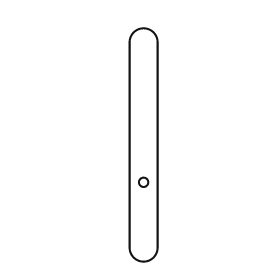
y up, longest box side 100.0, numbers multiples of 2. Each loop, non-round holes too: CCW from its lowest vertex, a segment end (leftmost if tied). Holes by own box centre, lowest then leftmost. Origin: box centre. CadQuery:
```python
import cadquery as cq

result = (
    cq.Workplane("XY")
    .moveTo(-6.0, -44.0)
    .threePointArc((0.0, -50.0), (6.0, -44.0))
    .lineTo(6.0, 44.0)
    .threePointArc((0.0, 50.0), (-6.0, 44.0))
    .close()
    .moveTo(0.0, -16.0)
    .circle(2.0)
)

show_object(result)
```